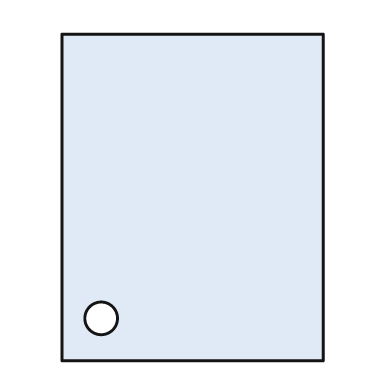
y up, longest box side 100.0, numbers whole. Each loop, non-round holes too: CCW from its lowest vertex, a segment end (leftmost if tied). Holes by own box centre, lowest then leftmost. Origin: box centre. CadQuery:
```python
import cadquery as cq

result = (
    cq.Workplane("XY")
    .moveTo(-40.0, -50.0)
    .lineTo(40.0, -50.0)
    .lineTo(40.0, 50.0)
    .lineTo(-40.0, 50.0)
    .close()
    .moveTo(-28.0, -37.0)
    .circle(5.0)
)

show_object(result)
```